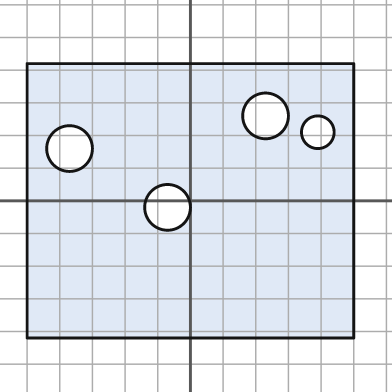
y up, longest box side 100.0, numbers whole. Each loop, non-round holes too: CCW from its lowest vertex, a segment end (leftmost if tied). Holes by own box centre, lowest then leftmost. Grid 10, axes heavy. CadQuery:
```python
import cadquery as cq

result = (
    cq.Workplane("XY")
    .moveTo(-50.0, -42.0)
    .lineTo(50.0, -42.0)
    .lineTo(50.0, 42.0)
    .lineTo(-50.0, 42.0)
    .close()
    .moveTo(-7.0, -2.0)
    .circle(7.0)
    .moveTo(-37.0, 16.0)
    .circle(7.0)
    .moveTo(39.0, 21.0)
    .circle(5.0)
    .moveTo(23.0, 26.0)
    .circle(7.0)
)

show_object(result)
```